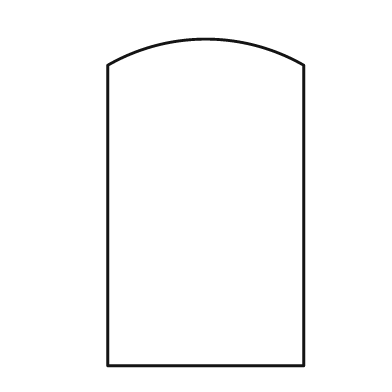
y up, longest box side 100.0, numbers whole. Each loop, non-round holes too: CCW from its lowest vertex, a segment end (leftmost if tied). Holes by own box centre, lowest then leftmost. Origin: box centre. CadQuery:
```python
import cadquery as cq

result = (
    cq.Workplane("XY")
    .moveTo(-30.0, -50.0)
    .lineTo(30.0, -50.0)
    .lineTo(30.0, 42.0)
    .threePointArc((0.0, 50.0), (-30.0, 42.0))
    .close()
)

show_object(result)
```